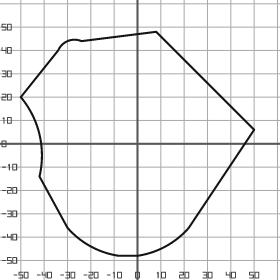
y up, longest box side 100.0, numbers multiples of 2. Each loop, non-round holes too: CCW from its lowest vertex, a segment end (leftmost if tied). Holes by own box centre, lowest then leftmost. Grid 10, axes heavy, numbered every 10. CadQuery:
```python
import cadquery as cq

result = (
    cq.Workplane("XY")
    .moveTo(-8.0, -48.0)
    .lineTo(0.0, -48.0)
    .threePointArc((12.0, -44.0), (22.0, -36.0))
    .lineTo(50.0, 6.0)
    .lineTo(8.0, 48.0)
    .lineTo(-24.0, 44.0)
    .threePointArc((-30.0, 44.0), (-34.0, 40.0))
    .lineTo(-50.0, 20.0)
    .threePointArc((-42.0, 4.0), (-42.0, -14.0))
    .lineTo(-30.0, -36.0)
    .threePointArc((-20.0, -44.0), (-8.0, -48.0))
    .close()
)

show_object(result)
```